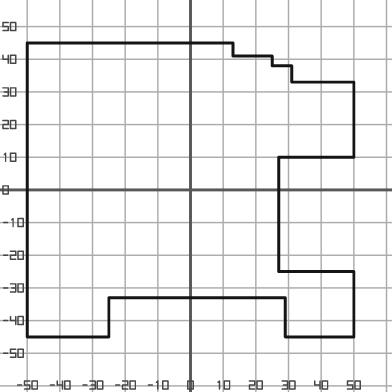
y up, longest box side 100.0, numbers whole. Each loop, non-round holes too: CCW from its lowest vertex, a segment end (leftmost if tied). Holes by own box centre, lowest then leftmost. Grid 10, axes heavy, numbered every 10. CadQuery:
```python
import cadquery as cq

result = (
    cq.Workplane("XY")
    .moveTo(-50.0, -45.0)
    .lineTo(-25.0, -45.0)
    .lineTo(-25.0, -33.0)
    .lineTo(29.0, -33.0)
    .lineTo(29.0, -45.0)
    .lineTo(50.0, -45.0)
    .lineTo(50.0, -25.0)
    .lineTo(27.0, -25.0)
    .lineTo(27.0, 10.0)
    .lineTo(50.0, 10.0)
    .lineTo(50.0, 33.0)
    .lineTo(31.0, 33.0)
    .lineTo(31.0, 38.0)
    .lineTo(25.0, 38.0)
    .lineTo(25.0, 41.0)
    .lineTo(13.0, 41.0)
    .lineTo(13.0, 45.0)
    .lineTo(-50.0, 45.0)
    .close()
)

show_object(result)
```